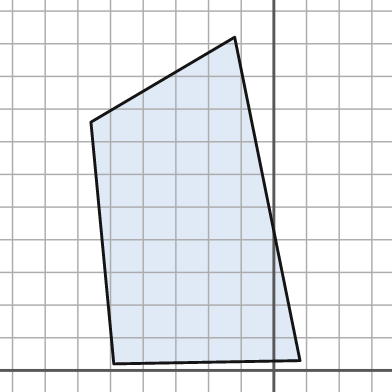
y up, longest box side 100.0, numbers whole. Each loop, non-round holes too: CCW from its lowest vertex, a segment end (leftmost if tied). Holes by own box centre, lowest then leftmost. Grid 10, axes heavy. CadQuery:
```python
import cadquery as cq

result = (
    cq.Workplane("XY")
    .moveTo(-49.0, 2.0)
    .lineTo(8.0, 3.0)
    .lineTo(-12.0, 102.0)
    .lineTo(-56.0, 76.0)
    .close()
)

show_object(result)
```